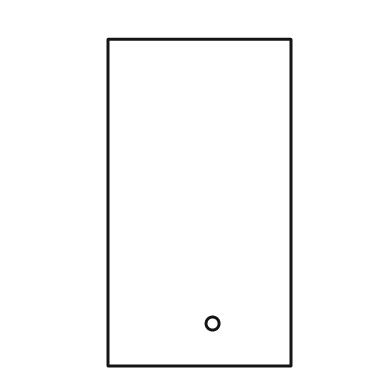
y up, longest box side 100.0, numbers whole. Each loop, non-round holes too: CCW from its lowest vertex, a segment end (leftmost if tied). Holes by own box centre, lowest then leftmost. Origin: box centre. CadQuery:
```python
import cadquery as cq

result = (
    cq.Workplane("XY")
    .moveTo(-28.0, -50.0)
    .lineTo(28.0, -50.0)
    .lineTo(28.0, 50.0)
    .lineTo(-28.0, 50.0)
    .close()
    .moveTo(4.0, -37.0)
    .circle(2.0)
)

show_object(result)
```